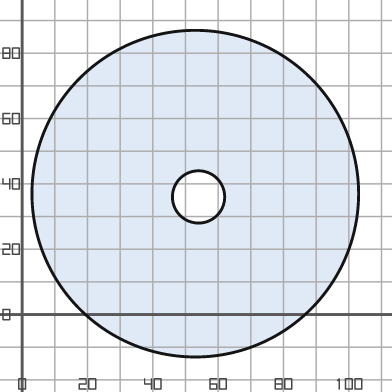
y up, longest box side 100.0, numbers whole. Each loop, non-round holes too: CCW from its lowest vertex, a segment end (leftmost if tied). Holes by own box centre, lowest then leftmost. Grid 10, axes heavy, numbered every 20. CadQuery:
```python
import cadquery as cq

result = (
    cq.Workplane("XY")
    .moveTo(53.0, 37.0)
    .circle(50.0)
    .moveTo(54.0, 36.0)
    .circle(8.0)
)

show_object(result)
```